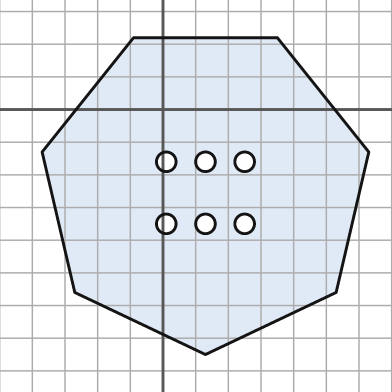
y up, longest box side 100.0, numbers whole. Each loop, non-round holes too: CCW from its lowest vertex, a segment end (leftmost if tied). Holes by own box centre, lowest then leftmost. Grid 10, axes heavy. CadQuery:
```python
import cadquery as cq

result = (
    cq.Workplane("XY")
    .moveTo(13.0, -75.0)
    .lineTo(53.0, -56.0)
    .lineTo(63.0, -13.0)
    .lineTo(35.0, 22.0)
    .lineTo(-9.0, 22.0)
    .lineTo(-37.0, -13.0)
    .lineTo(-27.0, -56.0)
    .close()
    .moveTo(1.0, -35.0)
    .circle(3.0)
    .moveTo(13.0, -35.0)
    .circle(3.0)
    .moveTo(25.0, -35.0)
    .circle(3.0)
    .moveTo(1.0, -16.0)
    .circle(3.0)
    .moveTo(13.0, -16.0)
    .circle(3.0)
    .moveTo(25.0, -16.0)
    .circle(3.0)
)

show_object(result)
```